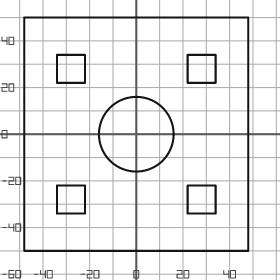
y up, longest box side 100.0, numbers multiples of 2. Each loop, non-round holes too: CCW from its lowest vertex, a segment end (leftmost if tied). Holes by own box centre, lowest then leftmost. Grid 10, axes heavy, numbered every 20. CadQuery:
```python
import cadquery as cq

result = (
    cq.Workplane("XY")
    .moveTo(-48.0, -50.0)
    .lineTo(48.0, -50.0)
    .lineTo(48.0, 50.0)
    .lineTo(-48.0, 50.0)
    .close()
    .moveTo(-34.0, -34.0)
    .lineTo(-22.0, -34.0)
    .lineTo(-22.0, -22.0)
    .lineTo(-34.0, -22.0)
    .close()
    .moveTo(22.0, -34.0)
    .lineTo(34.0, -34.0)
    .lineTo(34.0, -22.0)
    .lineTo(22.0, -22.0)
    .close()
    .moveTo(0.0, 0.0)
    .circle(16.0)
    .moveTo(-34.0, 22.0)
    .lineTo(-22.0, 22.0)
    .lineTo(-22.0, 34.0)
    .lineTo(-34.0, 34.0)
    .close()
    .moveTo(22.0, 22.0)
    .lineTo(34.0, 22.0)
    .lineTo(34.0, 34.0)
    .lineTo(22.0, 34.0)
    .close()
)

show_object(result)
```